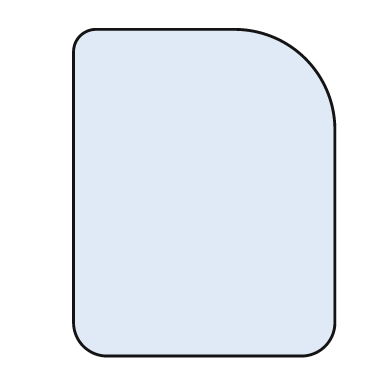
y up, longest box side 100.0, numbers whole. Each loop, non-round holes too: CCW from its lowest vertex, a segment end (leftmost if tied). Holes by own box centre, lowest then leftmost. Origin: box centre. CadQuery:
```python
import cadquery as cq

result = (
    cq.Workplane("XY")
    .moveTo(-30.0, -50.0)
    .lineTo(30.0, -50.0)
    .threePointArc((37.0, -47.0), (40.0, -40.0))
    .lineTo(40.0, 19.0)
    .threePointArc((31.0, 41.0), (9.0, 50.0))
    .lineTo(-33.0, 50.0)
    .threePointArc((-38.0, 48.0), (-40.0, 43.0))
    .lineTo(-40.0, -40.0)
    .threePointArc((-37.0, -47.0), (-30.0, -50.0))
    .close()
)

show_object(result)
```